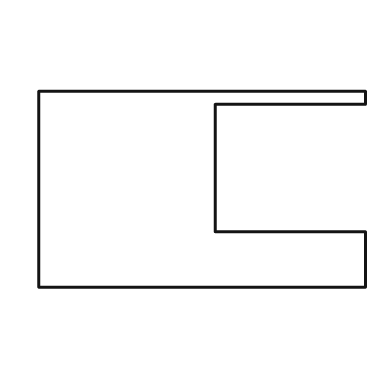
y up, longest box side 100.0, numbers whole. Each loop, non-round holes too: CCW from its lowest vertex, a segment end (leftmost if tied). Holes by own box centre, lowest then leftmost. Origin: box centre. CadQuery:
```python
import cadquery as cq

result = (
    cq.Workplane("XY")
    .moveTo(-50.0, -30.0)
    .lineTo(50.0, -30.0)
    .lineTo(50.0, -13.0)
    .lineTo(4.0, -13.0)
    .lineTo(4.0, 26.0)
    .lineTo(50.0, 26.0)
    .lineTo(50.0, 30.0)
    .lineTo(-50.0, 30.0)
    .close()
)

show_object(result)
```